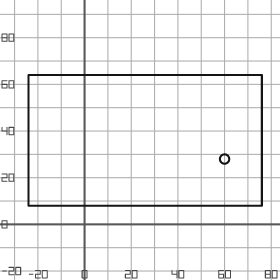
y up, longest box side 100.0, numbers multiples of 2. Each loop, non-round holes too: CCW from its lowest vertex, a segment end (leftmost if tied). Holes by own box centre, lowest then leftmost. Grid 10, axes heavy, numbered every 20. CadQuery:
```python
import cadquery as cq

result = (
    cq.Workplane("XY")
    .moveTo(-24.0, 8.0)
    .lineTo(76.0, 8.0)
    .lineTo(76.0, 64.0)
    .lineTo(-24.0, 64.0)
    .close()
    .moveTo(60.0, 28.0)
    .circle(2.0)
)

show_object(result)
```